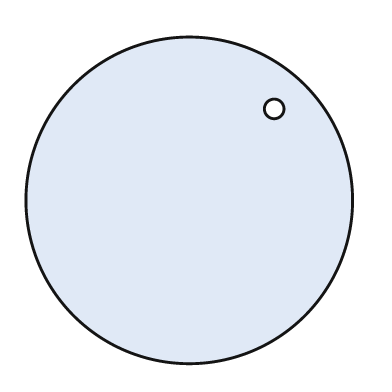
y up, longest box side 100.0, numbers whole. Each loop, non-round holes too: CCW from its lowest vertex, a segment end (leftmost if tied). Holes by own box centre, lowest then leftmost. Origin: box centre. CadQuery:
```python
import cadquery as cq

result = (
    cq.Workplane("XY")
    .moveTo(0.0, 0.0)
    .circle(50.0)
    .moveTo(26.0, 28.0)
    .circle(3.0)
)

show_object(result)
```